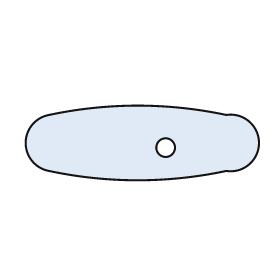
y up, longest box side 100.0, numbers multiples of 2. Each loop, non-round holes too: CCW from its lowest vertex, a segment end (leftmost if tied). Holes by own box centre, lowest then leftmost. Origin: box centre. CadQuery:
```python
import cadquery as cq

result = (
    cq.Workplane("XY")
    .moveTo(-40.0, -12.0)
    .threePointArc((-2.0, -16.0), (36.0, -12.0))
    .threePointArc((50.0, 0.0), (36.0, 12.0))
    .threePointArc((-2.0, 16.0), (-40.0, 12.0))
    .threePointArc((-50.0, 0.0), (-40.0, -12.0))
    .close()
    .moveTo(10.0, -2.0)
    .circle(4.0)
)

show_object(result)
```